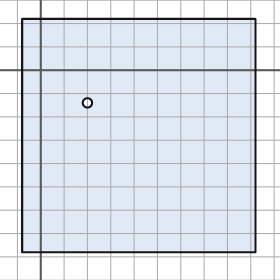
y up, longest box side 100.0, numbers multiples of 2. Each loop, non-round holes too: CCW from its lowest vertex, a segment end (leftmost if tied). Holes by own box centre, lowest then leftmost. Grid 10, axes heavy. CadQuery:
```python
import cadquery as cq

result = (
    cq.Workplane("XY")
    .moveTo(-8.0, -78.0)
    .lineTo(92.0, -78.0)
    .lineTo(92.0, 22.0)
    .lineTo(-8.0, 22.0)
    .close()
    .moveTo(20.0, -14.0)
    .circle(2.0)
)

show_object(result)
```